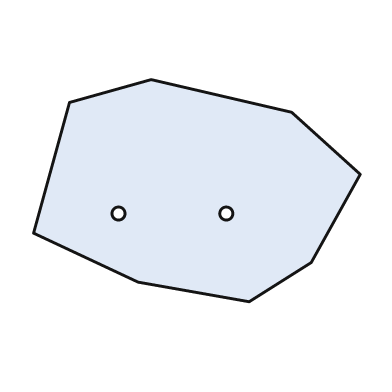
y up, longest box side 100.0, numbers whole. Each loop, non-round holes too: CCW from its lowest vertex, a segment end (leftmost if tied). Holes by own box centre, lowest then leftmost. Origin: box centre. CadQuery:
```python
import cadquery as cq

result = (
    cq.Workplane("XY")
    .moveTo(16.0, -34.0)
    .lineTo(35.0, -22.0)
    .lineTo(50.0, 5.0)
    .lineTo(29.0, 24.0)
    .lineTo(-14.0, 34.0)
    .lineTo(-39.0, 27.0)
    .lineTo(-50.0, -13.0)
    .lineTo(-18.0, -28.0)
    .close()
    .moveTo(-24.0, -7.0)
    .circle(2.0)
    .moveTo(9.0, -7.0)
    .circle(2.0)
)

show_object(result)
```